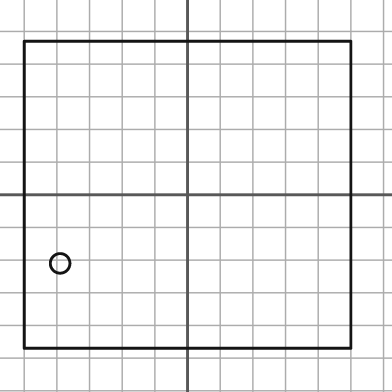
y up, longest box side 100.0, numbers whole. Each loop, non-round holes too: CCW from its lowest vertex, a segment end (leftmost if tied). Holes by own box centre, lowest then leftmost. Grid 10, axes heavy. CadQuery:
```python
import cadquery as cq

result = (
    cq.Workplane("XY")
    .moveTo(-50.0, -47.0)
    .lineTo(50.0, -47.0)
    .lineTo(50.0, 47.0)
    .lineTo(-50.0, 47.0)
    .close()
    .moveTo(-39.0, -21.0)
    .circle(3.0)
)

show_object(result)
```